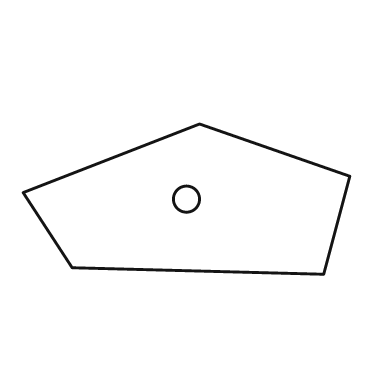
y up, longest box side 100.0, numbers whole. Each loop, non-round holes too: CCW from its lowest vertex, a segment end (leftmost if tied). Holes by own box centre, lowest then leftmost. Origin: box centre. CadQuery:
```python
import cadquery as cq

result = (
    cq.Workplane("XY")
    .moveTo(42.0, -23.0)
    .lineTo(50.0, 7.0)
    .lineTo(4.0, 23.0)
    .lineTo(-50.0, 2.0)
    .lineTo(-35.0, -21.0)
    .close()
    .moveTo(0.0, 0.0)
    .circle(4.0)
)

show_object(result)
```